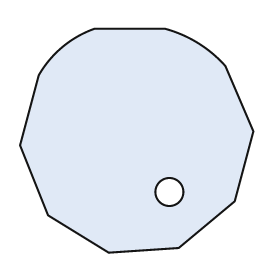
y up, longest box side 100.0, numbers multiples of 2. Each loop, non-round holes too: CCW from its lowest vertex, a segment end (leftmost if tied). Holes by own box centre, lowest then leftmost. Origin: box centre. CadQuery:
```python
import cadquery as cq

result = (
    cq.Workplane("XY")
    .moveTo(-12.0, -48.0)
    .lineTo(18.0, -46.0)
    .lineTo(42.0, -26.0)
    .lineTo(50.0, 4.0)
    .lineTo(38.0, 32.0)
    .threePointArc((26.0, 42.0), (12.0, 48.0))
    .lineTo(-18.0, 48.0)
    .threePointArc((-32.0, 40.0), (-42.0, 28.0))
    .lineTo(-50.0, -2.0)
    .lineTo(-38.0, -32.0)
    .close()
    .moveTo(14.0, -22.0)
    .circle(6.0)
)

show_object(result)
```